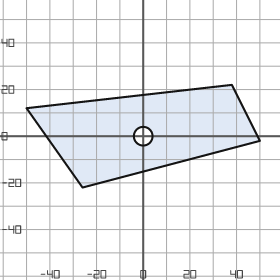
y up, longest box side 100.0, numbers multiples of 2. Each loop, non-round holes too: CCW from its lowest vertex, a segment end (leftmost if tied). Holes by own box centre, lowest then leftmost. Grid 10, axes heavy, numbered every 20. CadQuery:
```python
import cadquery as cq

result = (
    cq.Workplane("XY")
    .moveTo(-26.0, -22.0)
    .lineTo(50.0, -2.0)
    .lineTo(38.0, 22.0)
    .lineTo(-50.0, 12.0)
    .close()
    .moveTo(0.0, 0.0)
    .circle(4.0)
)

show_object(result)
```